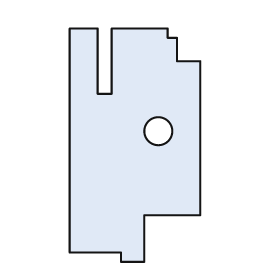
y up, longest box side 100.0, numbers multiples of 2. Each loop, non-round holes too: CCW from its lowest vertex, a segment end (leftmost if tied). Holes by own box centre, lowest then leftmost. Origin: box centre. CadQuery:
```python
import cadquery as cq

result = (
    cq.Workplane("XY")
    .moveTo(-6.0, -50.0)
    .lineTo(4.0, -50.0)
    .lineTo(4.0, -30.0)
    .lineTo(28.0, -30.0)
    .lineTo(28.0, 36.0)
    .lineTo(18.0, 36.0)
    .lineTo(18.0, 46.0)
    .lineTo(14.0, 46.0)
    .lineTo(14.0, 50.0)
    .lineTo(-10.0, 50.0)
    .lineTo(-10.0, 22.0)
    .lineTo(-16.0, 22.0)
    .lineTo(-16.0, 50.0)
    .lineTo(-28.0, 50.0)
    .lineTo(-28.0, -46.0)
    .lineTo(-6.0, -46.0)
    .close()
    .moveTo(10.0, 6.0)
    .circle(6.0)
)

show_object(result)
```